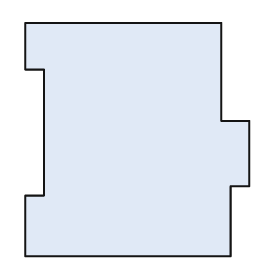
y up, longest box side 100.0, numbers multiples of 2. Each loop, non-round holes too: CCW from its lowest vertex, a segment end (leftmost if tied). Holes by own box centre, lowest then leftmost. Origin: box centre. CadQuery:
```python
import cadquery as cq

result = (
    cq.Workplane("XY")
    .moveTo(-48.0, -50.0)
    .lineTo(40.0, -50.0)
    .lineTo(40.0, -20.0)
    .lineTo(48.0, -20.0)
    .lineTo(48.0, 8.0)
    .lineTo(36.0, 8.0)
    .lineTo(36.0, 50.0)
    .lineTo(-48.0, 50.0)
    .lineTo(-48.0, 30.0)
    .lineTo(-40.0, 30.0)
    .lineTo(-40.0, -24.0)
    .lineTo(-48.0, -24.0)
    .close()
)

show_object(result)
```